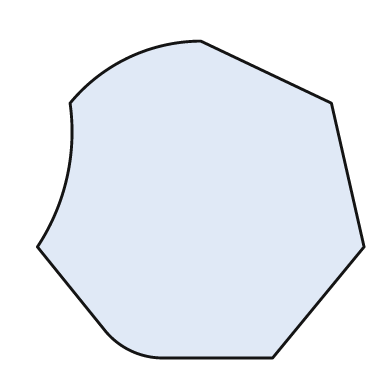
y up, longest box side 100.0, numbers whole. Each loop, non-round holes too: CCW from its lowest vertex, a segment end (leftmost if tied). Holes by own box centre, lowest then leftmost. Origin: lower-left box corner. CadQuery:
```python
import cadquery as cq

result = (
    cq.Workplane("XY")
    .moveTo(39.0, 0.0)
    .lineTo(72.0, 0.0)
    .lineTo(100.0, 34.0)
    .lineTo(90.0, 78.0)
    .lineTo(50.0, 97.0)
    .threePointArc((28.0, 92.0), (10.0, 78.0))
    .threePointArc((9.0, 55.0), (0.0, 34.0))
    .lineTo(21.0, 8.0)
    .threePointArc((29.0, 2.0), (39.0, 0.0))
    .close()
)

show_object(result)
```